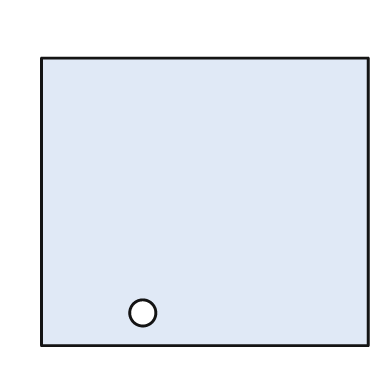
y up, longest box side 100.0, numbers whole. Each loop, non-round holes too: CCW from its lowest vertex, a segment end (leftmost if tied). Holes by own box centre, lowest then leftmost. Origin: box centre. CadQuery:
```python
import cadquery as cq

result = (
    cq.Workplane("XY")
    .moveTo(-50.0, -44.0)
    .lineTo(50.0, -44.0)
    .lineTo(50.0, 44.0)
    .lineTo(-50.0, 44.0)
    .close()
    .moveTo(-19.0, -34.0)
    .circle(4.0)
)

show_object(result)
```